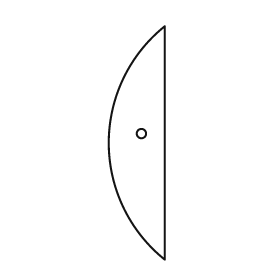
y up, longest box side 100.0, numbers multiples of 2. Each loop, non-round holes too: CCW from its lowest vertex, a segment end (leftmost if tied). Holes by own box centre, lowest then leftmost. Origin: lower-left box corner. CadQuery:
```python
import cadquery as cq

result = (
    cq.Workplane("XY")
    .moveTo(24.0, 0.0)
    .lineTo(24.0, 100.0)
    .threePointArc((0.0, 50.0), (24.0, 0.0))
    .close()
    .moveTo(14.0, 54.0)
    .circle(2.0)
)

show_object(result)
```